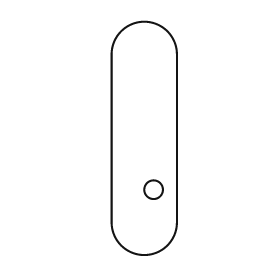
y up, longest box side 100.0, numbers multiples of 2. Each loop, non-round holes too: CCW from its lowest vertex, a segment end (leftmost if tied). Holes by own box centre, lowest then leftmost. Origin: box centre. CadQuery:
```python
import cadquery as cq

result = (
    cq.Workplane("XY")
    .moveTo(-14.0, -36.0)
    .threePointArc((0.0, -50.0), (14.0, -36.0))
    .lineTo(14.0, 36.0)
    .threePointArc((0.0, 50.0), (-14.0, 36.0))
    .close()
    .moveTo(4.0, -22.0)
    .circle(4.0)
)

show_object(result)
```